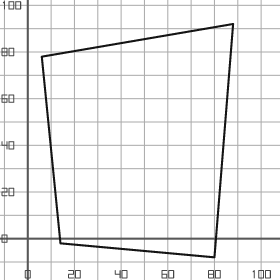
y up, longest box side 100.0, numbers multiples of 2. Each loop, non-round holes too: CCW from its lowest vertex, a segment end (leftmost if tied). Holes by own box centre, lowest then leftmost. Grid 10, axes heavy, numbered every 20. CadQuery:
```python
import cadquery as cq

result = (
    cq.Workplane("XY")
    .moveTo(80.0, -8.0)
    .lineTo(88.0, 92.0)
    .lineTo(6.0, 78.0)
    .lineTo(14.0, -2.0)
    .close()
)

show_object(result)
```